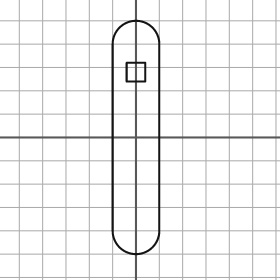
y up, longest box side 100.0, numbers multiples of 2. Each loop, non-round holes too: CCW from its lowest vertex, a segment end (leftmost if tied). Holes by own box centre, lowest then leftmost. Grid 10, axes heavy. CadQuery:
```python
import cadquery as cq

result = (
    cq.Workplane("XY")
    .moveTo(-10.0, -40.0)
    .threePointArc((0.0, -50.0), (10.0, -40.0))
    .lineTo(10.0, 40.0)
    .threePointArc((0.0, 50.0), (-10.0, 40.0))
    .close()
    .moveTo(-4.0, 24.0)
    .lineTo(4.0, 24.0)
    .lineTo(4.0, 32.0)
    .lineTo(-4.0, 32.0)
    .close()
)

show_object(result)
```